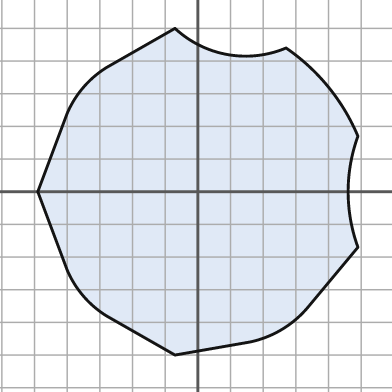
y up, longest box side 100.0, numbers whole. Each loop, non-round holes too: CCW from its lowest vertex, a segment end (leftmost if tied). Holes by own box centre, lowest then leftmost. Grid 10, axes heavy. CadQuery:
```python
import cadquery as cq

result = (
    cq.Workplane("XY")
    .moveTo(-7.0, -50.0)
    .lineTo(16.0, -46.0)
    .threePointArc((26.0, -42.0), (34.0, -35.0))
    .lineTo(49.0, -17.0)
    .threePointArc((46.0, 0.0), (49.0, 17.0))
    .threePointArc((40.0, 32.0), (27.0, 44.0))
    .threePointArc((9.0, 42.0), (-7.0, 50.0))
    .lineTo(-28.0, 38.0)
    .threePointArc((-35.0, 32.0), (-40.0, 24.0))
    .lineTo(-49.0, 0.0)
    .lineTo(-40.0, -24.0)
    .threePointArc((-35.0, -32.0), (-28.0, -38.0))
    .close()
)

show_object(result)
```